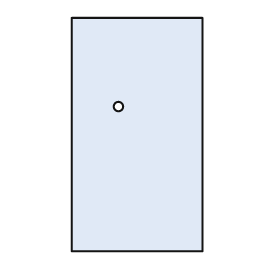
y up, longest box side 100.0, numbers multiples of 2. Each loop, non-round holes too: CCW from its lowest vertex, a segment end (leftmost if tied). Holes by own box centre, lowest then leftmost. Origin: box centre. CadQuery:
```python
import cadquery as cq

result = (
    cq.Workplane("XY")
    .moveTo(-28.0, -50.0)
    .lineTo(28.0, -50.0)
    .lineTo(28.0, 50.0)
    .lineTo(-28.0, 50.0)
    .close()
    .moveTo(-8.0, 12.0)
    .circle(2.0)
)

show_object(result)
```